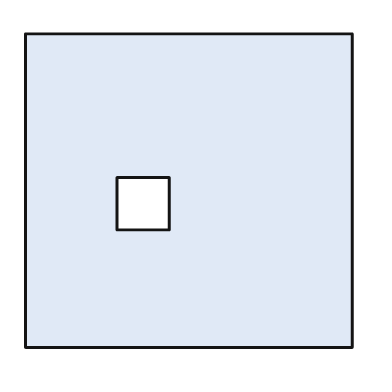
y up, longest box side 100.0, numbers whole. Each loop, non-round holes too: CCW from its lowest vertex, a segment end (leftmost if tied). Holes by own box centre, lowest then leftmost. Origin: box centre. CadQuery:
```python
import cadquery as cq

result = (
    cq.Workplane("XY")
    .moveTo(-50.0, -48.0)
    .lineTo(50.0, -48.0)
    .lineTo(50.0, 48.0)
    .lineTo(-50.0, 48.0)
    .close()
    .moveTo(-22.0, -12.0)
    .lineTo(-6.0, -12.0)
    .lineTo(-6.0, 4.0)
    .lineTo(-22.0, 4.0)
    .close()
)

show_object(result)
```